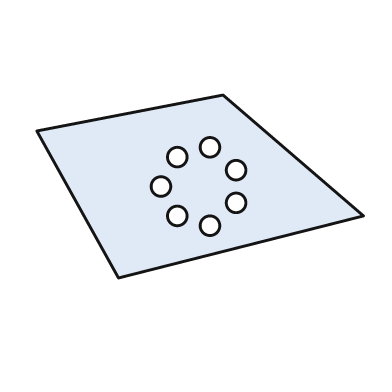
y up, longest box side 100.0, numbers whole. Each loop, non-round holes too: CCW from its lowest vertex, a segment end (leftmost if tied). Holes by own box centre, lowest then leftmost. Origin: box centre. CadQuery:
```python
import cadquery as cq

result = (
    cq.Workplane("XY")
    .moveTo(-25.0, -28.0)
    .lineTo(50.0, -9.0)
    .lineTo(7.0, 28.0)
    .lineTo(-50.0, 17.0)
    .close()
    .moveTo(3.0, -12.0)
    .circle(3.0)
    .moveTo(-7.0, -9.0)
    .circle(3.0)
    .moveTo(11.0, -5.0)
    .circle(3.0)
    .moveTo(-12.0, 0.0)
    .circle(3.0)
    .moveTo(11.0, 5.0)
    .circle(3.0)
    .moveTo(-7.0, 9.0)
    .circle(3.0)
    .moveTo(3.0, 12.0)
    .circle(3.0)
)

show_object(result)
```